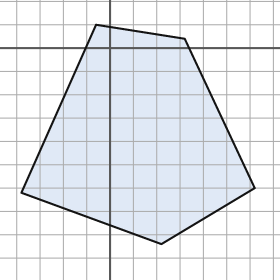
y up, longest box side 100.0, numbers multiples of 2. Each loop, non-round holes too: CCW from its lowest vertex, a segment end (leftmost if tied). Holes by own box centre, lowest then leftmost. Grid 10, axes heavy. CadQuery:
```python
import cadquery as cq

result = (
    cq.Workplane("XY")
    .moveTo(22.0, -84.0)
    .lineTo(62.0, -60.0)
    .lineTo(32.0, 4.0)
    .lineTo(-6.0, 10.0)
    .lineTo(-38.0, -62.0)
    .close()
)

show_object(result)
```